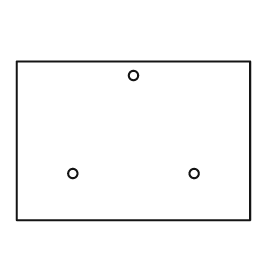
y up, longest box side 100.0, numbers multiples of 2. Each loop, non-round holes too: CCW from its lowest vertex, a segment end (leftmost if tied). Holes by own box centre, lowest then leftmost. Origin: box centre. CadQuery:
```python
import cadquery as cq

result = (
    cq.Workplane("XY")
    .moveTo(-50.0, -34.0)
    .lineTo(50.0, -34.0)
    .lineTo(50.0, 34.0)
    .lineTo(-50.0, 34.0)
    .close()
    .moveTo(-26.0, -14.0)
    .circle(2.0)
    .moveTo(26.0, -14.0)
    .circle(2.0)
    .moveTo(0.0, 28.0)
    .circle(2.0)
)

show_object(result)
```